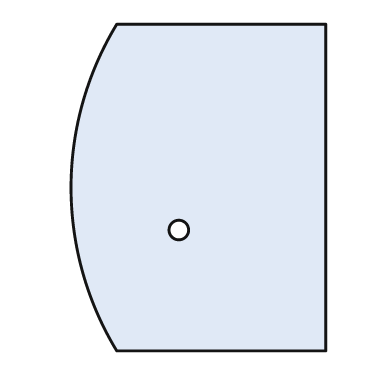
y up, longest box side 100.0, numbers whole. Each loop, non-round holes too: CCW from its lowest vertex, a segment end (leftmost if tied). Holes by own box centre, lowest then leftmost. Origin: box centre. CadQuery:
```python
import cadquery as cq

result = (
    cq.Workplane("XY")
    .moveTo(-25.0, -50.0)
    .lineTo(39.0, -50.0)
    .lineTo(39.0, 50.0)
    .lineTo(-25.0, 50.0)
    .threePointArc((-39.0, 0.0), (-25.0, -50.0))
    .close()
    .moveTo(-6.0, -13.0)
    .circle(3.0)
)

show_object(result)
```